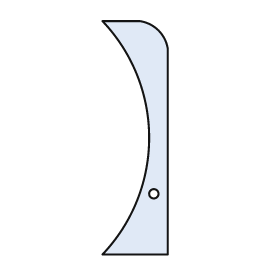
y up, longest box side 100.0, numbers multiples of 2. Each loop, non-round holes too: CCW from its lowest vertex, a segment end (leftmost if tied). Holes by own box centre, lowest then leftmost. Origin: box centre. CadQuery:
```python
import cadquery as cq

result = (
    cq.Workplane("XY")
    .moveTo(-14.0, -50.0)
    .lineTo(14.0, -50.0)
    .lineTo(14.0, 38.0)
    .threePointArc((10.0, 46.0), (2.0, 50.0))
    .lineTo(-14.0, 50.0)
    .threePointArc((6.0, 0.0), (-14.0, -50.0))
    .close()
    .moveTo(8.0, -24.0)
    .circle(2.0)
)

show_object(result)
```